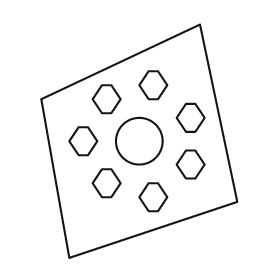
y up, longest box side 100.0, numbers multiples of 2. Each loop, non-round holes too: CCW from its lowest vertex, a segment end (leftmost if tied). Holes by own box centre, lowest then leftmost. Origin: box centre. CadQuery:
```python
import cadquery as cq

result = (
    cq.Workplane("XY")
    .moveTo(-30.0, -50.0)
    .lineTo(42.0, -26.0)
    .lineTo(26.0, 50.0)
    .lineTo(-42.0, 18.0)
    .close()
    .moveTo(4.0, -30.0)
    .lineTo(8.0, -30.0)
    .lineTo(12.0, -24.0)
    .lineTo(8.0, -18.0)
    .lineTo(4.0, -18.0)
    .lineTo(0.0, -24.0)
    .close()
    .moveTo(-16.0, -24.0)
    .lineTo(-12.0, -24.0)
    .lineTo(-8.0, -18.0)
    .lineTo(-12.0, -12.0)
    .lineTo(-16.0, -12.0)
    .lineTo(-20.0, -18.0)
    .close()
    .moveTo(20.0, -16.0)
    .lineTo(24.0, -16.0)
    .lineTo(28.0, -10.0)
    .lineTo(24.0, -4.0)
    .lineTo(20.0, -4.0)
    .lineTo(16.0, -10.0)
    .close()
    .moveTo(-26.0, -6.0)
    .lineTo(-22.0, -6.0)
    .lineTo(-18.0, 0.0)
    .lineTo(-22.0, 6.0)
    .lineTo(-26.0, 6.0)
    .lineTo(-30.0, 0.0)
    .close()
    .moveTo(0.0, 0.0)
    .circle(10.0)
    .moveTo(20.0, 4.0)
    .lineTo(24.0, 4.0)
    .lineTo(28.0, 10.0)
    .lineTo(24.0, 16.0)
    .lineTo(20.0, 16.0)
    .lineTo(16.0, 10.0)
    .close()
    .moveTo(-16.0, 12.0)
    .lineTo(-12.0, 12.0)
    .lineTo(-8.0, 18.0)
    .lineTo(-12.0, 24.0)
    .lineTo(-16.0, 24.0)
    .lineTo(-20.0, 18.0)
    .close()
    .moveTo(4.0, 18.0)
    .lineTo(8.0, 18.0)
    .lineTo(12.0, 24.0)
    .lineTo(8.0, 30.0)
    .lineTo(4.0, 30.0)
    .lineTo(0.0, 24.0)
    .close()
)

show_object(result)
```